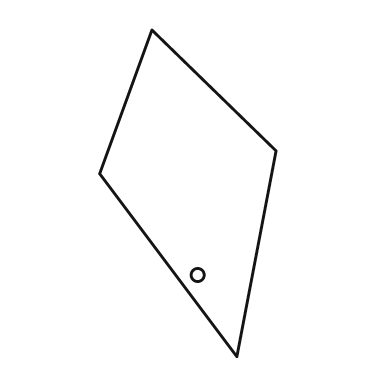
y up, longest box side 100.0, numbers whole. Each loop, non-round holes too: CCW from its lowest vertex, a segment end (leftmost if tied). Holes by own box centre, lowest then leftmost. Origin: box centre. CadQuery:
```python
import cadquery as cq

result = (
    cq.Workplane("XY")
    .moveTo(15.0, -50.0)
    .lineTo(27.0, 13.0)
    .lineTo(-11.0, 50.0)
    .lineTo(-27.0, 6.0)
    .close()
    .moveTo(3.0, -25.0)
    .circle(2.0)
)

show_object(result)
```